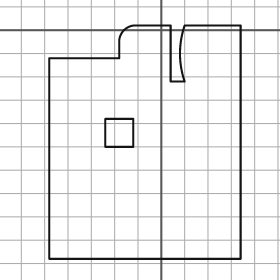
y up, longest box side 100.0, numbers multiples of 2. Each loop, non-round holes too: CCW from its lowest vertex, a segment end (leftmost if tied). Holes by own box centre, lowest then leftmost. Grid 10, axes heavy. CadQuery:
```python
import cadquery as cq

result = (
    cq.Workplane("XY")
    .moveTo(-48.0, -98.0)
    .lineTo(34.0, -98.0)
    .lineTo(34.0, 2.0)
    .lineTo(10.0, 2.0)
    .threePointArc((8.0, -10.0), (10.0, -22.0))
    .lineTo(4.0, -22.0)
    .lineTo(4.0, 2.0)
    .lineTo(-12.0, 2.0)
    .threePointArc((-16.0, 0.0), (-18.0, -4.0))
    .lineTo(-18.0, -12.0)
    .lineTo(-48.0, -12.0)
    .close()
    .moveTo(-24.0, -50.0)
    .lineTo(-12.0, -50.0)
    .lineTo(-12.0, -38.0)
    .lineTo(-24.0, -38.0)
    .close()
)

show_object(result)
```